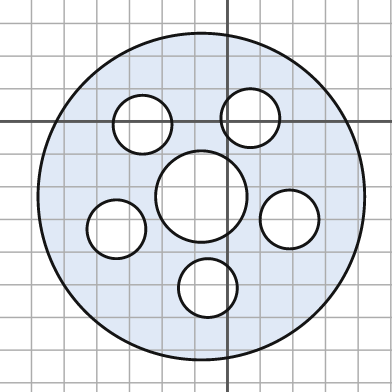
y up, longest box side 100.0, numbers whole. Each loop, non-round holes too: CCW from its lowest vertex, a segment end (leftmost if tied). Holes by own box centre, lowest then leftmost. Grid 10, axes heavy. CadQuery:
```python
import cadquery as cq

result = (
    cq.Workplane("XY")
    .moveTo(-8.0, -23.0)
    .circle(50.0)
    .moveTo(-6.0, -51.0)
    .circle(9.0)
    .moveTo(-34.0, -33.0)
    .circle(9.0)
    .moveTo(19.0, -30.0)
    .circle(9.0)
    .moveTo(-8.0, -23.0)
    .circle(14.0)
    .moveTo(-26.0, -1.0)
    .circle(9.0)
    .moveTo(7.0, 1.0)
    .circle(9.0)
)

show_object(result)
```